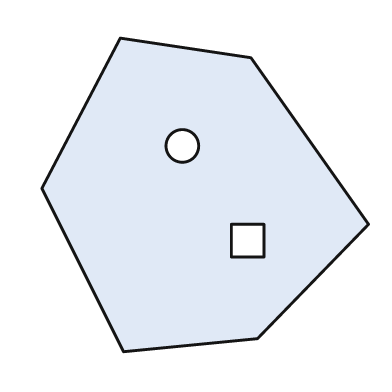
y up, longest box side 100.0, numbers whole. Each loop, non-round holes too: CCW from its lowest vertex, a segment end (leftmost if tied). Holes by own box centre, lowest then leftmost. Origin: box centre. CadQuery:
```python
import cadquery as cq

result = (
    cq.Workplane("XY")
    .moveTo(-25.0, -48.0)
    .lineTo(16.0, -44.0)
    .lineTo(50.0, -9.0)
    .lineTo(14.0, 42.0)
    .lineTo(-26.0, 48.0)
    .lineTo(-50.0, 2.0)
    .close()
    .moveTo(8.0, -19.0)
    .lineTo(18.0, -19.0)
    .lineTo(18.0, -9.0)
    .lineTo(8.0, -9.0)
    .close()
    .moveTo(-7.0, 15.0)
    .circle(5.0)
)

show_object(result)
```